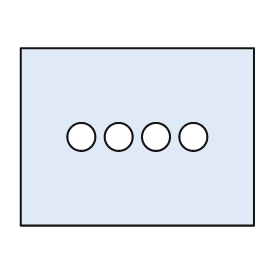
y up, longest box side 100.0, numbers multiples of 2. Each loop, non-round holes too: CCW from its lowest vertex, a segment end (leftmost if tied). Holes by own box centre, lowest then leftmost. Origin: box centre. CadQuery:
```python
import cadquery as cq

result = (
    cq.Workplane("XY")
    .moveTo(-50.0, -38.0)
    .lineTo(50.0, -38.0)
    .lineTo(50.0, 38.0)
    .lineTo(-50.0, 38.0)
    .close()
    .moveTo(-24.0, 0.0)
    .circle(6.0)
    .moveTo(-8.0, 0.0)
    .circle(6.0)
    .moveTo(8.0, 0.0)
    .circle(6.0)
    .moveTo(24.0, 0.0)
    .circle(6.0)
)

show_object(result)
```